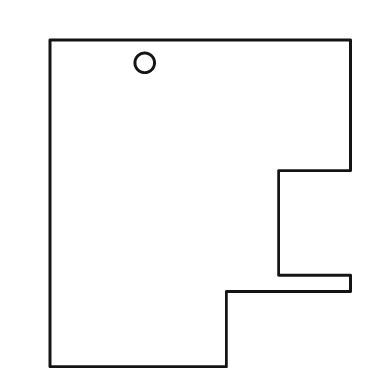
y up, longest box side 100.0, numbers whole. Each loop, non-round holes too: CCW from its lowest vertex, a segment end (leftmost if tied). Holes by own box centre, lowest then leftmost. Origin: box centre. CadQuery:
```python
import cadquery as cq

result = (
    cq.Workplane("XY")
    .moveTo(-46.0, -50.0)
    .lineTo(8.0, -50.0)
    .lineTo(8.0, -27.0)
    .lineTo(46.0, -27.0)
    .lineTo(46.0, -22.0)
    .lineTo(24.0, -22.0)
    .lineTo(24.0, 10.0)
    .lineTo(46.0, 10.0)
    .lineTo(46.0, 50.0)
    .lineTo(-46.0, 50.0)
    .close()
    .moveTo(-17.0, 43.0)
    .circle(3.0)
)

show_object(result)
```